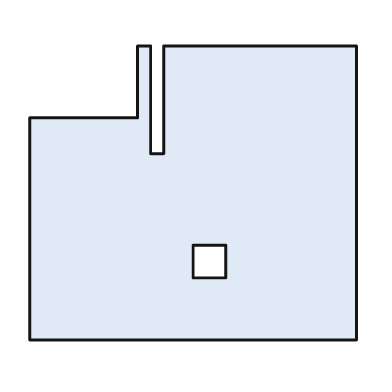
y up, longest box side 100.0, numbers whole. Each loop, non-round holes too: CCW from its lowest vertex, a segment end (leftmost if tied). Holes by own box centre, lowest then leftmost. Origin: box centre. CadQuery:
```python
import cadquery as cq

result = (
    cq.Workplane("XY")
    .moveTo(-50.0, -45.0)
    .lineTo(50.0, -45.0)
    .lineTo(50.0, 45.0)
    .lineTo(-9.0, 45.0)
    .lineTo(-9.0, 12.0)
    .lineTo(-13.0, 12.0)
    .lineTo(-13.0, 45.0)
    .lineTo(-17.0, 45.0)
    .lineTo(-17.0, 23.0)
    .lineTo(-50.0, 23.0)
    .close()
    .moveTo(0.0, -26.0)
    .lineTo(10.0, -26.0)
    .lineTo(10.0, -16.0)
    .lineTo(0.0, -16.0)
    .close()
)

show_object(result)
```